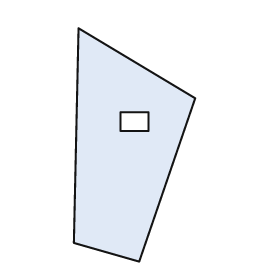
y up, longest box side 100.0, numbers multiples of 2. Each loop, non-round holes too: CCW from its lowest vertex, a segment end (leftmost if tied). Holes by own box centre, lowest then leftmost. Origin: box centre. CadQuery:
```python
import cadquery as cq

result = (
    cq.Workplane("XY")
    .moveTo(2.0, -50.0)
    .lineTo(26.0, 20.0)
    .lineTo(-24.0, 50.0)
    .lineTo(-26.0, -42.0)
    .close()
    .moveTo(-6.0, 6.0)
    .lineTo(6.0, 6.0)
    .lineTo(6.0, 14.0)
    .lineTo(-6.0, 14.0)
    .close()
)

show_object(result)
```